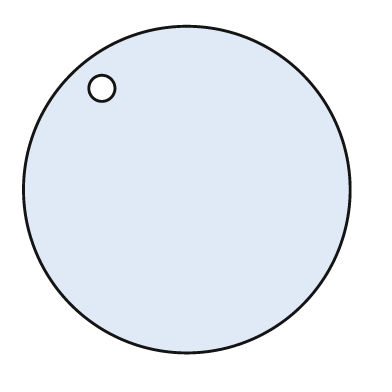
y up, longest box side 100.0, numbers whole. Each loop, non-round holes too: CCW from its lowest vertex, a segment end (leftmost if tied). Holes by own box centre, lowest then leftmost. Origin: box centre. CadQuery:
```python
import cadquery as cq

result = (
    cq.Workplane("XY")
    .moveTo(0.0, 0.0)
    .circle(50.0)
    .moveTo(-26.0, 31.0)
    .circle(4.0)
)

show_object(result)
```